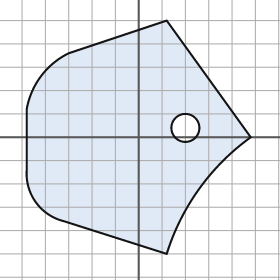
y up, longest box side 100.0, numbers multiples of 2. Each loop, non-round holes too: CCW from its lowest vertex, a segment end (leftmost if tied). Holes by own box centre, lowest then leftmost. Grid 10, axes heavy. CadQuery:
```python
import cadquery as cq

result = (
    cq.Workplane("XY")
    .moveTo(12.0, -50.0)
    .threePointArc((26.0, -22.0), (48.0, 0.0))
    .lineTo(12.0, 50.0)
    .lineTo(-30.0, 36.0)
    .threePointArc((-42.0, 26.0), (-48.0, 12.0))
    .lineTo(-48.0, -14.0)
    .threePointArc((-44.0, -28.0), (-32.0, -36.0))
    .close()
    .moveTo(20.0, 4.0)
    .circle(6.0)
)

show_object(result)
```